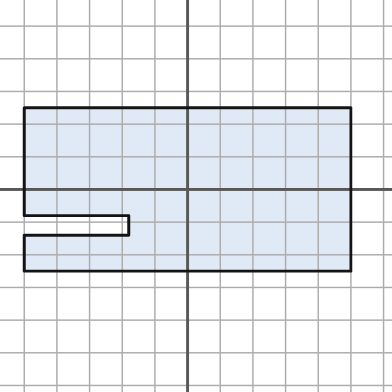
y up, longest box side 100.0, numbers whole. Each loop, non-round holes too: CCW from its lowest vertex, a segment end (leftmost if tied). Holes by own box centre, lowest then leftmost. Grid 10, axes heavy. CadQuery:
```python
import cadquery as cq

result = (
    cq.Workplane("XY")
    .moveTo(-50.0, -25.0)
    .lineTo(50.0, -25.0)
    .lineTo(50.0, 25.0)
    .lineTo(-50.0, 25.0)
    .lineTo(-50.0, -8.0)
    .lineTo(-18.0, -8.0)
    .lineTo(-18.0, -14.0)
    .lineTo(-50.0, -14.0)
    .close()
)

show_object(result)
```